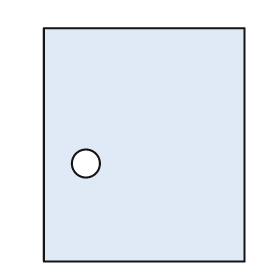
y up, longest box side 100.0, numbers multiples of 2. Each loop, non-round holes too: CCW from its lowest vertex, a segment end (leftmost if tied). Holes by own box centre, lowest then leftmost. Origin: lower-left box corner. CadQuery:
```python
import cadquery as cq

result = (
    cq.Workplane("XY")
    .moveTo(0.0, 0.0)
    .lineTo(86.0, 0.0)
    .lineTo(86.0, 100.0)
    .lineTo(0.0, 100.0)
    .close()
    .moveTo(18.0, 42.0)
    .circle(6.0)
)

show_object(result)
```